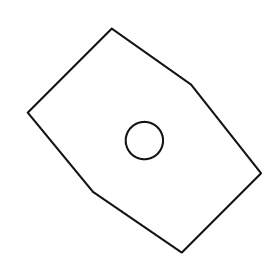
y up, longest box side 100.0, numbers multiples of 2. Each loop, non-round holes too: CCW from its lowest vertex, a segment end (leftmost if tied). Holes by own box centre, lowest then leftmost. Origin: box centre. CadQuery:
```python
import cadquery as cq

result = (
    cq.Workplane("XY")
    .moveTo(16.0, -48.0)
    .lineTo(50.0, -14.0)
    .lineTo(20.0, 24.0)
    .lineTo(-14.0, 48.0)
    .lineTo(-50.0, 12.0)
    .lineTo(-22.0, -22.0)
    .close()
    .moveTo(0.0, 0.0)
    .circle(8.0)
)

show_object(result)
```